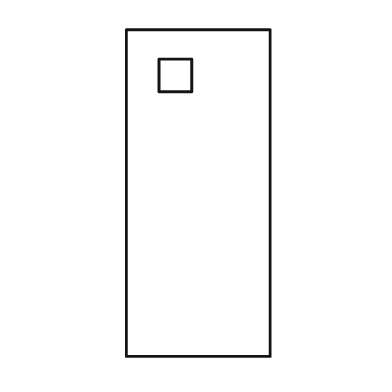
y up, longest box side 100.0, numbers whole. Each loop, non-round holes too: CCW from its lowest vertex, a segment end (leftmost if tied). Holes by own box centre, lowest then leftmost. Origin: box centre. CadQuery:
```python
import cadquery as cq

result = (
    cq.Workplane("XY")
    .moveTo(-22.0, -50.0)
    .lineTo(22.0, -50.0)
    .lineTo(22.0, 50.0)
    .lineTo(-22.0, 50.0)
    .close()
    .moveTo(-12.0, 31.0)
    .lineTo(-2.0, 31.0)
    .lineTo(-2.0, 41.0)
    .lineTo(-12.0, 41.0)
    .close()
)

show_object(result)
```